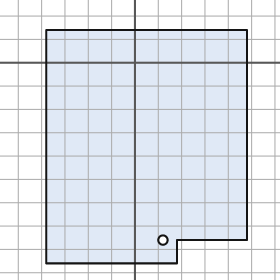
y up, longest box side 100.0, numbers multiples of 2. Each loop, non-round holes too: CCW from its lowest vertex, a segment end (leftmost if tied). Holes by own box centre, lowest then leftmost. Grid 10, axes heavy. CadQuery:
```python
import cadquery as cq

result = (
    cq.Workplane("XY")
    .moveTo(-38.0, -86.0)
    .lineTo(18.0, -86.0)
    .lineTo(18.0, -76.0)
    .lineTo(48.0, -76.0)
    .lineTo(48.0, 14.0)
    .lineTo(-38.0, 14.0)
    .close()
    .moveTo(12.0, -76.0)
    .circle(2.0)
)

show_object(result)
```